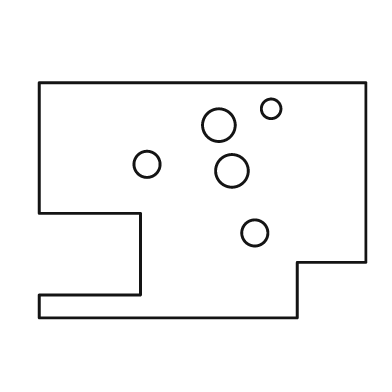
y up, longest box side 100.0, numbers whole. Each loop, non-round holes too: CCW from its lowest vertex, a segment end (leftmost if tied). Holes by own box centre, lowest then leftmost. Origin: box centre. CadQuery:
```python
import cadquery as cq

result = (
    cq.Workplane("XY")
    .moveTo(-50.0, -36.0)
    .lineTo(29.0, -36.0)
    .lineTo(29.0, -19.0)
    .lineTo(50.0, -19.0)
    .lineTo(50.0, 36.0)
    .lineTo(-50.0, 36.0)
    .lineTo(-50.0, -4.0)
    .lineTo(-19.0, -4.0)
    .lineTo(-19.0, -29.0)
    .lineTo(-50.0, -29.0)
    .close()
    .moveTo(16.0, -10.0)
    .circle(4.0)
    .moveTo(9.0, 9.0)
    .circle(5.0)
    .moveTo(-17.0, 11.0)
    .circle(4.0)
    .moveTo(5.0, 23.0)
    .circle(5.0)
    .moveTo(21.0, 28.0)
    .circle(3.0)
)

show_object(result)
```